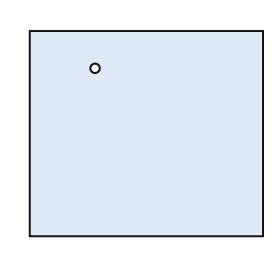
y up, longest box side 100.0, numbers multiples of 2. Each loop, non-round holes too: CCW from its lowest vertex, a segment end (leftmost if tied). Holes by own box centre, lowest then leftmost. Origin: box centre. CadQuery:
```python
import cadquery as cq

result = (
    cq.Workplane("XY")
    .moveTo(-50.0, -44.0)
    .lineTo(50.0, -44.0)
    .lineTo(50.0, 44.0)
    .lineTo(-50.0, 44.0)
    .close()
    .moveTo(-22.0, 28.0)
    .circle(2.0)
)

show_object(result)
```